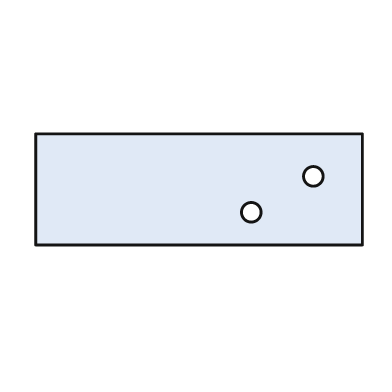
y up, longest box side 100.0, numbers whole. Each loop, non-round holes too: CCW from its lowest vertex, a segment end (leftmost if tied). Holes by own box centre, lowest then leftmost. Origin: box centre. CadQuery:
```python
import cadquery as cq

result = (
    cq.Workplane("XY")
    .moveTo(-50.0, -17.0)
    .lineTo(50.0, -17.0)
    .lineTo(50.0, 17.0)
    .lineTo(-50.0, 17.0)
    .close()
    .moveTo(16.0, -7.0)
    .circle(3.0)
    .moveTo(35.0, 4.0)
    .circle(3.0)
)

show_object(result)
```